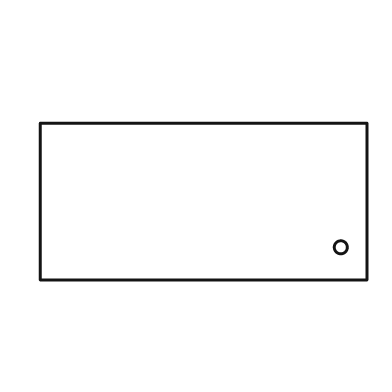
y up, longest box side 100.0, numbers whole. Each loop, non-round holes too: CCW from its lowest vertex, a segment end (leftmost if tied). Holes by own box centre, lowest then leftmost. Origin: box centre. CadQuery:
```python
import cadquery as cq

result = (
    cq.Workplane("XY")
    .moveTo(-50.0, -24.0)
    .lineTo(50.0, -24.0)
    .lineTo(50.0, 24.0)
    .lineTo(-50.0, 24.0)
    .close()
    .moveTo(42.0, -14.0)
    .circle(2.0)
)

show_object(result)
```